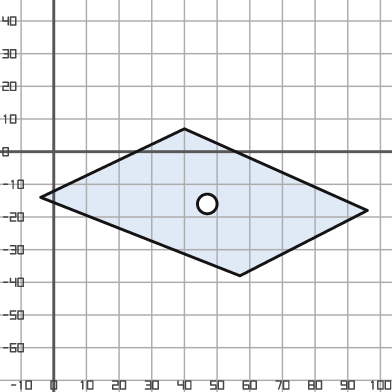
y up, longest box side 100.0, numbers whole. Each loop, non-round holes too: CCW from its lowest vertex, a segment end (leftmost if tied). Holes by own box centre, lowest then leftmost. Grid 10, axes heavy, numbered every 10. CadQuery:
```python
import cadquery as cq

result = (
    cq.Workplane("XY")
    .moveTo(57.0, -38.0)
    .lineTo(96.0, -18.0)
    .lineTo(40.0, 7.0)
    .lineTo(-4.0, -14.0)
    .close()
    .moveTo(47.0, -16.0)
    .circle(3.0)
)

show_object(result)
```